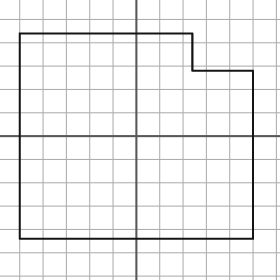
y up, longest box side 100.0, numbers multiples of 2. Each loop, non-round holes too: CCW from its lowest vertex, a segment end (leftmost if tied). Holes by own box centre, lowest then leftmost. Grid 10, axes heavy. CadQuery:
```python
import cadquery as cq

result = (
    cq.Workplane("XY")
    .moveTo(-50.0, -44.0)
    .lineTo(50.0, -44.0)
    .lineTo(50.0, 28.0)
    .lineTo(24.0, 28.0)
    .lineTo(24.0, 44.0)
    .lineTo(-50.0, 44.0)
    .close()
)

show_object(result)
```